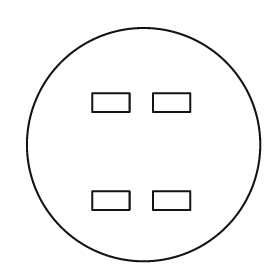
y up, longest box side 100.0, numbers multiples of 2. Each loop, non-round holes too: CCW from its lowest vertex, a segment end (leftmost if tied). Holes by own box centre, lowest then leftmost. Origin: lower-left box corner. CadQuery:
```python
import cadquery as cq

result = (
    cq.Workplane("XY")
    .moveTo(50.0, 50.0)
    .circle(50.0)
    .moveTo(28.0, 22.0)
    .lineTo(44.0, 22.0)
    .lineTo(44.0, 30.0)
    .lineTo(28.0, 30.0)
    .close()
    .moveTo(54.0, 22.0)
    .lineTo(70.0, 22.0)
    .lineTo(70.0, 30.0)
    .lineTo(54.0, 30.0)
    .close()
    .moveTo(28.0, 64.0)
    .lineTo(44.0, 64.0)
    .lineTo(44.0, 72.0)
    .lineTo(28.0, 72.0)
    .close()
    .moveTo(54.0, 64.0)
    .lineTo(70.0, 64.0)
    .lineTo(70.0, 72.0)
    .lineTo(54.0, 72.0)
    .close()
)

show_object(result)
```